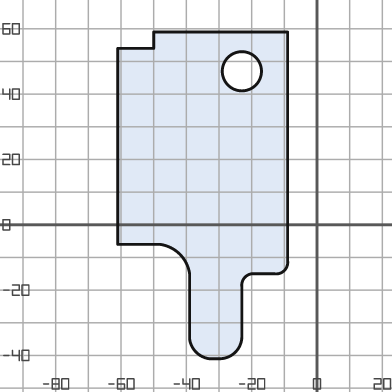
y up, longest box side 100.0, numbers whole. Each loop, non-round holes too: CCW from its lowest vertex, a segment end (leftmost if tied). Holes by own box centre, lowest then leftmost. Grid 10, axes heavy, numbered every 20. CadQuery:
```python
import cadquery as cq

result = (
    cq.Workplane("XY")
    .moveTo(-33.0, -41.0)
    .lineTo(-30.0, -41.0)
    .threePointArc((-25.0, -39.0), (-23.0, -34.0))
    .lineTo(-23.0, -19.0)
    .threePointArc((-22.0, -16.0), (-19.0, -15.0))
    .lineTo(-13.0, -15.0)
    .threePointArc((-10.0, -14.0), (-9.0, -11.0))
    .lineTo(-9.0, 59.0)
    .lineTo(-50.0, 59.0)
    .lineTo(-50.0, 54.0)
    .lineTo(-61.0, 54.0)
    .lineTo(-61.0, -6.0)
    .lineTo(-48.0, -6.0)
    .threePointArc((-42.0, -9.0), (-39.0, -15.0))
    .lineTo(-39.0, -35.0)
    .threePointArc((-37.0, -39.0), (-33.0, -41.0))
    .close()
    .moveTo(-23.0, 47.0)
    .circle(6.0)
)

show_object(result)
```